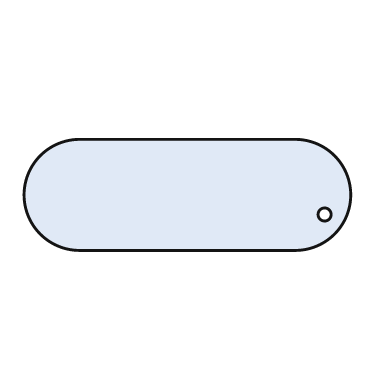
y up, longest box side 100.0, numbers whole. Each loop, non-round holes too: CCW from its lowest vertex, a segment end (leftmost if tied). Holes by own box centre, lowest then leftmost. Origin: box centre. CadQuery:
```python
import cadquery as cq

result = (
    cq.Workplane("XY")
    .moveTo(-33.0, -17.0)
    .lineTo(33.0, -17.0)
    .threePointArc((50.0, 0.0), (33.0, 17.0))
    .lineTo(-33.0, 17.0)
    .threePointArc((-50.0, 0.0), (-33.0, -17.0))
    .close()
    .moveTo(42.0, -6.0)
    .circle(2.0)
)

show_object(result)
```